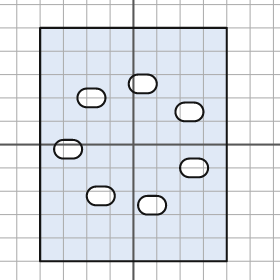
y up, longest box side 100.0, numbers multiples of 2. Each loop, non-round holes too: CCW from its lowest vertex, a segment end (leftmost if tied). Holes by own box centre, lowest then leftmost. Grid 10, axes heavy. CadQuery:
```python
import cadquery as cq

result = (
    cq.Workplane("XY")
    .moveTo(-40.0, -50.0)
    .lineTo(40.0, -50.0)
    .lineTo(40.0, 50.0)
    .lineTo(-40.0, 50.0)
    .close()
    .moveTo(6.0, -30.0)
    .lineTo(10.0, -30.0)
    .threePointArc((14.0, -26.0), (10.0, -22.0))
    .lineTo(6.0, -22.0)
    .threePointArc((2.0, -26.0), (6.0, -30.0))
    .close()
    .moveTo(-16.0, -26.0)
    .lineTo(-12.0, -26.0)
    .threePointArc((-8.0, -22.0), (-12.0, -18.0))
    .lineTo(-16.0, -18.0)
    .threePointArc((-20.0, -22.0), (-16.0, -26.0))
    .close()
    .moveTo(24.0, -14.0)
    .lineTo(28.0, -14.0)
    .threePointArc((32.0, -10.0), (28.0, -6.0))
    .lineTo(24.0, -6.0)
    .threePointArc((20.0, -10.0), (24.0, -14.0))
    .close()
    .moveTo(-30.0, -6.0)
    .lineTo(-26.0, -6.0)
    .threePointArc((-22.0, -2.0), (-26.0, 2.0))
    .lineTo(-30.0, 2.0)
    .threePointArc((-34.0, -2.0), (-30.0, -6.0))
    .close()
    .moveTo(22.0, 10.0)
    .lineTo(26.0, 10.0)
    .threePointArc((30.0, 14.0), (26.0, 18.0))
    .lineTo(22.0, 18.0)
    .threePointArc((18.0, 14.0), (22.0, 10.0))
    .close()
    .moveTo(-20.0, 16.0)
    .lineTo(-16.0, 16.0)
    .threePointArc((-12.0, 20.0), (-16.0, 24.0))
    .lineTo(-20.0, 24.0)
    .threePointArc((-24.0, 20.0), (-20.0, 16.0))
    .close()
    .moveTo(2.0, 22.0)
    .lineTo(6.0, 22.0)
    .threePointArc((10.0, 26.0), (6.0, 30.0))
    .lineTo(2.0, 30.0)
    .threePointArc((-2.0, 26.0), (2.0, 22.0))
    .close()
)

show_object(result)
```